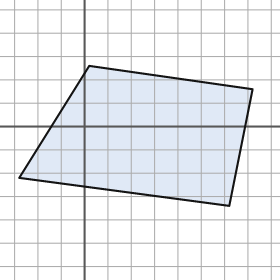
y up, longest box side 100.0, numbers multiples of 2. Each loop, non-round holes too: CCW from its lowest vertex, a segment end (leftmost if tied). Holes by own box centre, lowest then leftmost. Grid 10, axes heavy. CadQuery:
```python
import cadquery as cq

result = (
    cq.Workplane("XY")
    .moveTo(62.0, -34.0)
    .lineTo(72.0, 16.0)
    .lineTo(2.0, 26.0)
    .lineTo(-28.0, -22.0)
    .close()
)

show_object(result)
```